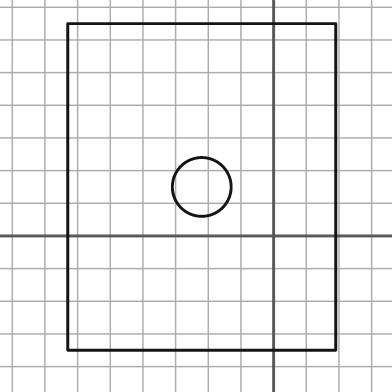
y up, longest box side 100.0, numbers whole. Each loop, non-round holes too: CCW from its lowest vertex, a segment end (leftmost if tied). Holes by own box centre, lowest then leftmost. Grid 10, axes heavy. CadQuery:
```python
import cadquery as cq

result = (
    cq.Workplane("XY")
    .moveTo(-63.0, -35.0)
    .lineTo(19.0, -35.0)
    .lineTo(19.0, 65.0)
    .lineTo(-63.0, 65.0)
    .close()
    .moveTo(-22.0, 15.0)
    .circle(9.0)
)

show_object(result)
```